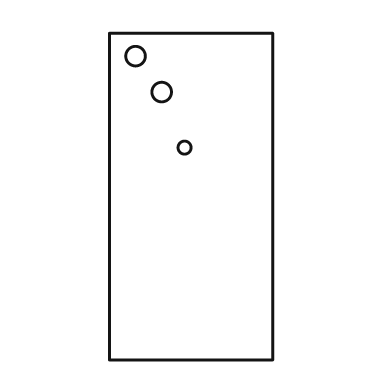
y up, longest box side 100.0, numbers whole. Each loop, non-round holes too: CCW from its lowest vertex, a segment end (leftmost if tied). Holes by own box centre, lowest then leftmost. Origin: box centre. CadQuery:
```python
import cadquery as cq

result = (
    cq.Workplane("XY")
    .moveTo(-25.0, -50.0)
    .lineTo(25.0, -50.0)
    .lineTo(25.0, 50.0)
    .lineTo(-25.0, 50.0)
    .close()
    .moveTo(-2.0, 15.0)
    .circle(2.0)
    .moveTo(-9.0, 32.0)
    .circle(3.0)
    .moveTo(-17.0, 43.0)
    .circle(3.0)
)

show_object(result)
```